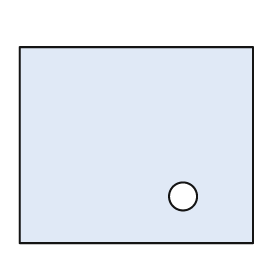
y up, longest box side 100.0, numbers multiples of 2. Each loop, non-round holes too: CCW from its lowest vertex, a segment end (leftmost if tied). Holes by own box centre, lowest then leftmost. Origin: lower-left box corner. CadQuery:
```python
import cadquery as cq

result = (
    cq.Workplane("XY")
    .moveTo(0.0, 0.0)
    .lineTo(100.0, 0.0)
    .lineTo(100.0, 84.0)
    .lineTo(0.0, 84.0)
    .close()
    .moveTo(70.0, 20.0)
    .circle(6.0)
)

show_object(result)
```